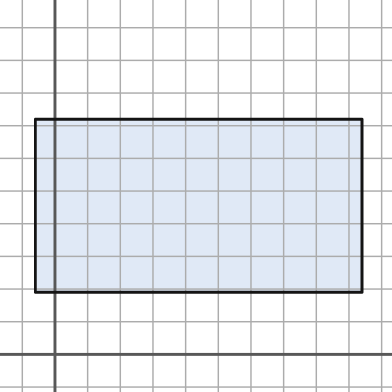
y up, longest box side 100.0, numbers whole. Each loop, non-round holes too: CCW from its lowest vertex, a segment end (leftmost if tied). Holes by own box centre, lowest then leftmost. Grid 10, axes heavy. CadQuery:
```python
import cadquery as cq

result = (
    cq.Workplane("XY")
    .moveTo(-6.0, 19.0)
    .lineTo(94.0, 19.0)
    .lineTo(94.0, 72.0)
    .lineTo(-6.0, 72.0)
    .close()
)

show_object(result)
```